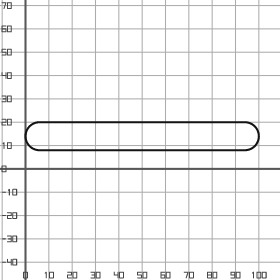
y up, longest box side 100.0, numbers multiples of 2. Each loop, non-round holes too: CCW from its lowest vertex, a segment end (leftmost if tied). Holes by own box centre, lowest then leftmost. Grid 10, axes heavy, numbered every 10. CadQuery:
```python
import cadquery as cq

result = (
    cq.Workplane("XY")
    .moveTo(6.0, 8.0)
    .lineTo(94.0, 8.0)
    .threePointArc((100.0, 14.0), (94.0, 20.0))
    .lineTo(6.0, 20.0)
    .threePointArc((0.0, 14.0), (6.0, 8.0))
    .close()
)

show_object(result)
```